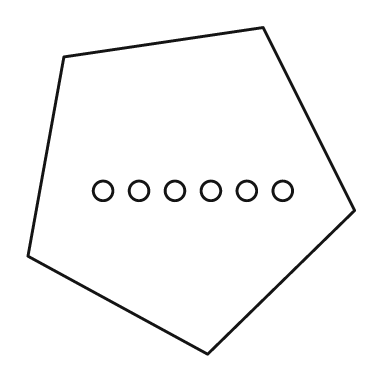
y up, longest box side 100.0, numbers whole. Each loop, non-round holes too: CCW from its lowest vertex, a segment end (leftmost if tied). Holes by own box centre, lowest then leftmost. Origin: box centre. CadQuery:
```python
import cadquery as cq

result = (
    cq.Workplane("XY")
    .moveTo(5.0, -50.0)
    .lineTo(50.0, -6.0)
    .lineTo(22.0, 50.0)
    .lineTo(-39.0, 41.0)
    .lineTo(-50.0, -20.0)
    .close()
    .moveTo(-27.0, 0.0)
    .circle(3.0)
    .moveTo(-16.0, 0.0)
    .circle(3.0)
    .moveTo(-5.0, 0.0)
    .circle(3.0)
    .moveTo(6.0, 0.0)
    .circle(3.0)
    .moveTo(17.0, 0.0)
    .circle(3.0)
    .moveTo(28.0, 0.0)
    .circle(3.0)
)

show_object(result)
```